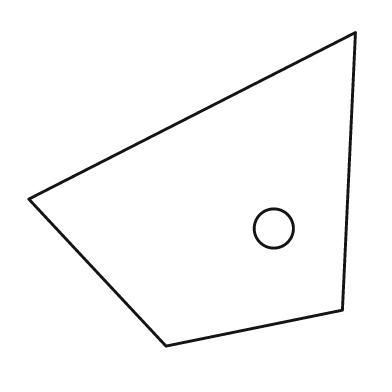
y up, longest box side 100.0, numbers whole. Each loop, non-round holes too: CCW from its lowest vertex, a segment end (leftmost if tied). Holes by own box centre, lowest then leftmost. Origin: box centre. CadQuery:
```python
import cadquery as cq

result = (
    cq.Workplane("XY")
    .moveTo(-8.0, -48.0)
    .lineTo(46.0, -37.0)
    .lineTo(50.0, 48.0)
    .lineTo(-50.0, -3.0)
    .close()
    .moveTo(25.0, -12.0)
    .circle(6.0)
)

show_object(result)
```